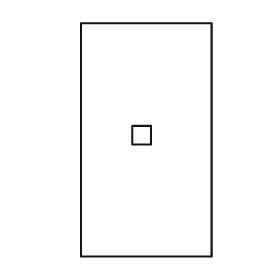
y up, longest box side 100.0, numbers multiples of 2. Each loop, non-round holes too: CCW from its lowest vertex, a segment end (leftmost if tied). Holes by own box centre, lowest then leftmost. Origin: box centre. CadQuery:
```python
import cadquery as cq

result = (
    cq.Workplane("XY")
    .moveTo(-28.0, -50.0)
    .lineTo(28.0, -50.0)
    .lineTo(28.0, 50.0)
    .lineTo(-28.0, 50.0)
    .close()
    .moveTo(-6.0, -2.0)
    .lineTo(2.0, -2.0)
    .lineTo(2.0, 6.0)
    .lineTo(-6.0, 6.0)
    .close()
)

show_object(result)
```